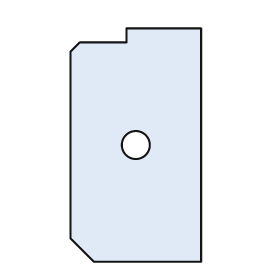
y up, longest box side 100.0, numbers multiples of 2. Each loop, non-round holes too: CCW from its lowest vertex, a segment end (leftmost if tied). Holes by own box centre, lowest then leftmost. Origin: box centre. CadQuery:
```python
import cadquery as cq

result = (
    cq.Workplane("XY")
    .moveTo(-18.0, -50.0)
    .lineTo(28.0, -50.0)
    .lineTo(28.0, 50.0)
    .lineTo(-4.0, 50.0)
    .lineTo(-4.0, 44.0)
    .lineTo(-24.0, 44.0)
    .lineTo(-28.0, 40.0)
    .lineTo(-28.0, -40.0)
    .close()
    .moveTo(0.0, 0.0)
    .circle(6.0)
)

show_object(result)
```